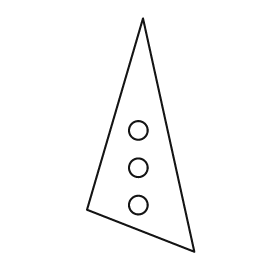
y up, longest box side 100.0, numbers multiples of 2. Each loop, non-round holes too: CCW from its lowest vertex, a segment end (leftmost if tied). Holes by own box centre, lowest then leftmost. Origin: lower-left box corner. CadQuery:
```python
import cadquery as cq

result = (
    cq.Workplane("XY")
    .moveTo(46.0, 0.0)
    .lineTo(24.0, 100.0)
    .lineTo(0.0, 18.0)
    .close()
    .moveTo(22.0, 20.0)
    .circle(4.0)
    .moveTo(22.0, 36.0)
    .circle(4.0)
    .moveTo(22.0, 52.0)
    .circle(4.0)
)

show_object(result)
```